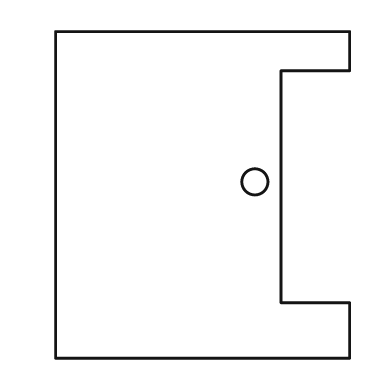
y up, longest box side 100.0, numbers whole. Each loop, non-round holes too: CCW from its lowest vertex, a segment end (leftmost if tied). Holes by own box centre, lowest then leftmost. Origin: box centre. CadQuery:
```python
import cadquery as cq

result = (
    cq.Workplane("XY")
    .moveTo(-45.0, -50.0)
    .lineTo(45.0, -50.0)
    .lineTo(45.0, -33.0)
    .lineTo(24.0, -33.0)
    .lineTo(24.0, 38.0)
    .lineTo(45.0, 38.0)
    .lineTo(45.0, 50.0)
    .lineTo(-45.0, 50.0)
    .close()
    .moveTo(16.0, 4.0)
    .circle(4.0)
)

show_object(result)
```